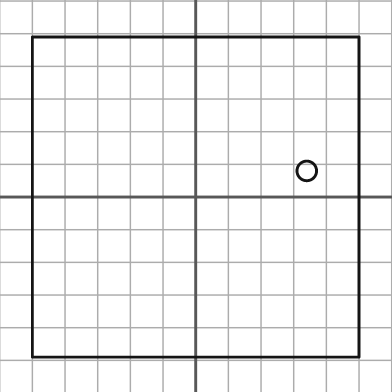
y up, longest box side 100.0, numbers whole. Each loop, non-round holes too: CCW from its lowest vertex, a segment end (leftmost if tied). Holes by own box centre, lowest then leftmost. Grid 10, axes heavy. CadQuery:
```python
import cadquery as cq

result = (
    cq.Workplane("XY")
    .moveTo(-50.0, -49.0)
    .lineTo(50.0, -49.0)
    .lineTo(50.0, 49.0)
    .lineTo(-50.0, 49.0)
    .close()
    .moveTo(34.0, 8.0)
    .circle(3.0)
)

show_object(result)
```